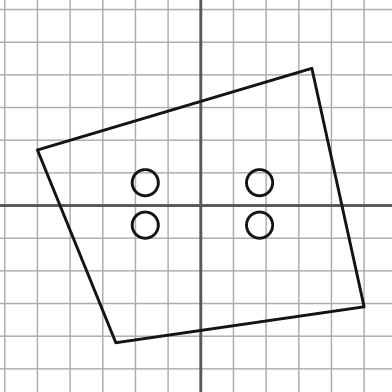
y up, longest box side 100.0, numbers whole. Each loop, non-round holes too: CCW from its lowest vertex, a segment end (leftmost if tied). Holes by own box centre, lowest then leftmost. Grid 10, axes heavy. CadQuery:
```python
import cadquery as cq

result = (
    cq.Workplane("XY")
    .moveTo(-26.0, -42.0)
    .lineTo(50.0, -31.0)
    .lineTo(34.0, 42.0)
    .lineTo(-50.0, 17.0)
    .close()
    .moveTo(-17.0, -6.0)
    .circle(4.0)
    .moveTo(18.0, -6.0)
    .circle(4.0)
    .moveTo(-17.0, 7.0)
    .circle(4.0)
    .moveTo(18.0, 7.0)
    .circle(4.0)
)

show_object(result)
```